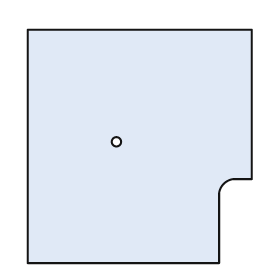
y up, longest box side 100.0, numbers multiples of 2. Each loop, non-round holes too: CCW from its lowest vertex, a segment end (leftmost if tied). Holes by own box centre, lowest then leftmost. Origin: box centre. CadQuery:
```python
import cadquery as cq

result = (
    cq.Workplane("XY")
    .moveTo(-48.0, -50.0)
    .lineTo(34.0, -50.0)
    .lineTo(34.0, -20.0)
    .threePointArc((36.0, -16.0), (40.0, -14.0))
    .lineTo(48.0, -14.0)
    .lineTo(48.0, 50.0)
    .lineTo(-48.0, 50.0)
    .close()
    .moveTo(-10.0, 2.0)
    .circle(2.0)
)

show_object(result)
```